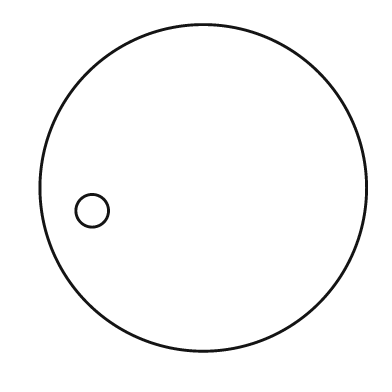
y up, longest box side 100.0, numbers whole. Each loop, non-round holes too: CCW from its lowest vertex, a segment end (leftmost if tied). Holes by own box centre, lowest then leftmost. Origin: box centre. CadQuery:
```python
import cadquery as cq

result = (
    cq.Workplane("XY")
    .moveTo(0.0, 0.0)
    .circle(50.0)
    .moveTo(-34.0, -7.0)
    .circle(5.0)
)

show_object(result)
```